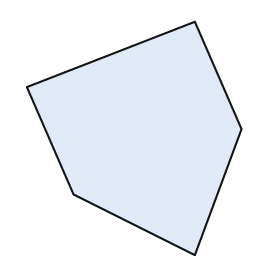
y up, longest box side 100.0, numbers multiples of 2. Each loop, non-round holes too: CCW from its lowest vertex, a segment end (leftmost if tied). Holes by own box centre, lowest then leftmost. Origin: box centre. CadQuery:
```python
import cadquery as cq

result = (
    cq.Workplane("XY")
    .moveTo(26.0, -50.0)
    .lineTo(46.0, 4.0)
    .lineTo(26.0, 50.0)
    .lineTo(-46.0, 22.0)
    .lineTo(-26.0, -24.0)
    .close()
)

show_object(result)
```